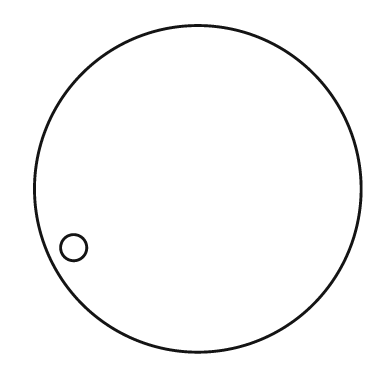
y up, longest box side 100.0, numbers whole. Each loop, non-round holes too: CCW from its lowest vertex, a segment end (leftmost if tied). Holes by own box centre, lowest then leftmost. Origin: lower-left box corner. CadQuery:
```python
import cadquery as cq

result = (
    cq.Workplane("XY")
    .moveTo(50.0, 50.0)
    .circle(50.0)
    .moveTo(12.0, 32.0)
    .circle(4.0)
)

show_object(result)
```